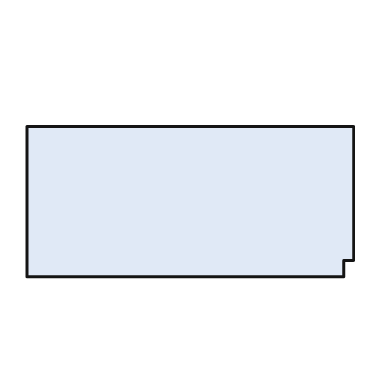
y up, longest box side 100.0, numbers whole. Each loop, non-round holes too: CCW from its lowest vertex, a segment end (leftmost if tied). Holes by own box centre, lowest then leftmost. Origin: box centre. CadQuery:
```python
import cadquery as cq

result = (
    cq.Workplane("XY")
    .moveTo(-50.0, -23.0)
    .lineTo(47.0, -23.0)
    .lineTo(47.0, -18.0)
    .lineTo(50.0, -18.0)
    .lineTo(50.0, 23.0)
    .lineTo(-50.0, 23.0)
    .close()
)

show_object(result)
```